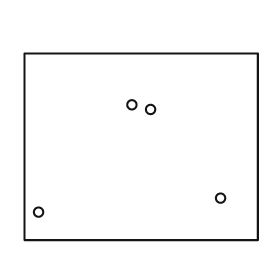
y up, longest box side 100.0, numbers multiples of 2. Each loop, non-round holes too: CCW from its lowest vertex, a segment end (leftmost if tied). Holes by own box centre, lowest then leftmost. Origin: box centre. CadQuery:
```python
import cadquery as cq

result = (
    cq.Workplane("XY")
    .moveTo(-50.0, -40.0)
    .lineTo(50.0, -40.0)
    .lineTo(50.0, 40.0)
    .lineTo(-50.0, 40.0)
    .close()
    .moveTo(-44.0, -28.0)
    .circle(2.0)
    .moveTo(34.0, -22.0)
    .circle(2.0)
    .moveTo(4.0, 16.0)
    .circle(2.0)
    .moveTo(-4.0, 18.0)
    .circle(2.0)
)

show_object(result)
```